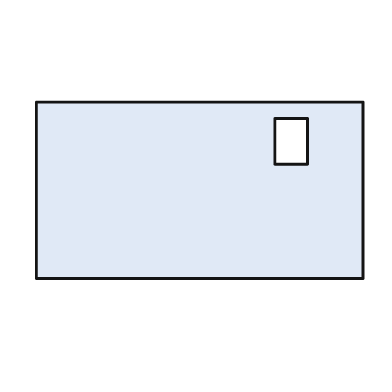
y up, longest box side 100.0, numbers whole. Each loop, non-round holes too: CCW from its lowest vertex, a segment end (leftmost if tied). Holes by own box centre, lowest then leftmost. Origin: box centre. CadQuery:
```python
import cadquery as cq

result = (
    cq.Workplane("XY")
    .moveTo(-50.0, -27.0)
    .lineTo(50.0, -27.0)
    .lineTo(50.0, 27.0)
    .lineTo(-50.0, 27.0)
    .close()
    .moveTo(23.0, 8.0)
    .lineTo(33.0, 8.0)
    .lineTo(33.0, 22.0)
    .lineTo(23.0, 22.0)
    .close()
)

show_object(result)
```